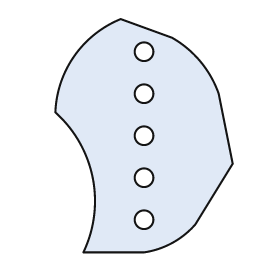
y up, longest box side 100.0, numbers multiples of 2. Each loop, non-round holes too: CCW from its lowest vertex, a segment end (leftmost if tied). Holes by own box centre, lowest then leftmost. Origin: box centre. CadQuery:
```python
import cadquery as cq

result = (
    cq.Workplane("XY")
    .moveTo(-26.0, -50.0)
    .lineTo(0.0, -50.0)
    .threePointArc((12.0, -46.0), (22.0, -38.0))
    .lineTo(38.0, -12.0)
    .lineTo(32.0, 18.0)
    .threePointArc((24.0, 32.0), (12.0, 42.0))
    .lineTo(-10.0, 50.0)
    .threePointArc((-30.0, 34.0), (-38.0, 10.0))
    .threePointArc((-22.0, -18.0), (-26.0, -50.0))
    .close()
    .moveTo(0.0, -36.0)
    .circle(4.0)
    .moveTo(0.0, -18.0)
    .circle(4.0)
    .moveTo(0.0, 0.0)
    .circle(4.0)
    .moveTo(0.0, 18.0)
    .circle(4.0)
    .moveTo(0.0, 36.0)
    .circle(4.0)
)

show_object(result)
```